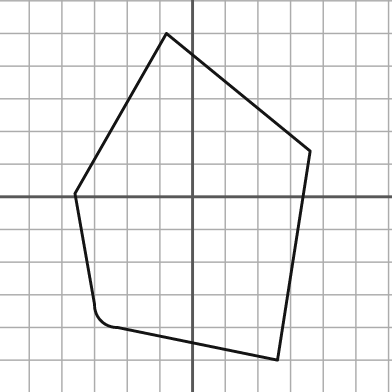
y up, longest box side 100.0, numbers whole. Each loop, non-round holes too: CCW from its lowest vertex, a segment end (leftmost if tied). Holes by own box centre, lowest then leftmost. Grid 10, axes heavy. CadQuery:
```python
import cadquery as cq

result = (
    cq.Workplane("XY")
    .moveTo(26.0, -50.0)
    .lineTo(36.0, 14.0)
    .lineTo(-8.0, 50.0)
    .lineTo(-36.0, 1.0)
    .lineTo(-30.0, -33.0)
    .threePointArc((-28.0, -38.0), (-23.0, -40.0))
    .close()
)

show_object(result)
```